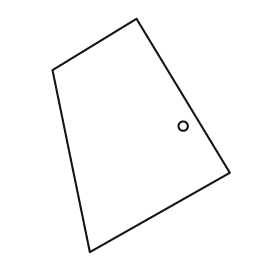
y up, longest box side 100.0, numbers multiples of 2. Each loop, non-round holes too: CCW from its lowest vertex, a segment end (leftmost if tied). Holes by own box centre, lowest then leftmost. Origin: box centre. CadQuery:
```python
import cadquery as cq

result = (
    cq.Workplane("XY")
    .moveTo(-22.0, -50.0)
    .lineTo(38.0, -16.0)
    .lineTo(-2.0, 50.0)
    .lineTo(-38.0, 28.0)
    .close()
    .moveTo(18.0, 4.0)
    .circle(2.0)
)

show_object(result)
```